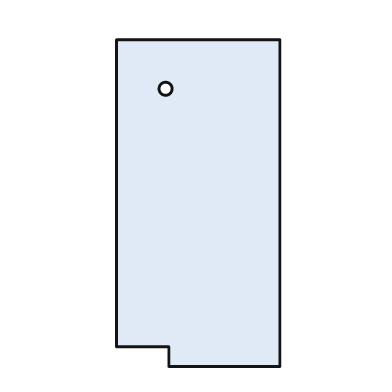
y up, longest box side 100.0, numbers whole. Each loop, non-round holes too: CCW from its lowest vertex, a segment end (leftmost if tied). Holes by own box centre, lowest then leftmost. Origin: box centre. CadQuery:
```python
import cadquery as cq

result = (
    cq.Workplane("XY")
    .moveTo(-9.0, -50.0)
    .lineTo(25.0, -50.0)
    .lineTo(25.0, 50.0)
    .lineTo(-25.0, 50.0)
    .lineTo(-25.0, -44.0)
    .lineTo(-9.0, -44.0)
    .close()
    .moveTo(-10.0, 35.0)
    .circle(2.0)
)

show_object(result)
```